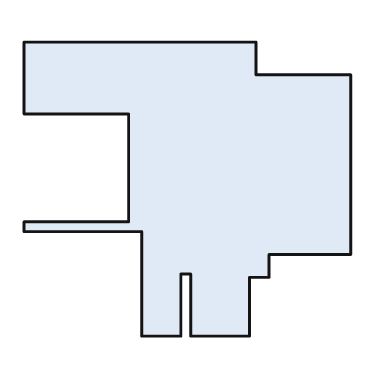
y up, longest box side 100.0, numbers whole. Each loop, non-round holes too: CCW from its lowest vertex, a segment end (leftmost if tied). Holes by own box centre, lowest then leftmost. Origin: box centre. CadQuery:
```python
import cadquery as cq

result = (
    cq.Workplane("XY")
    .moveTo(-14.0, -45.0)
    .lineTo(-2.0, -45.0)
    .lineTo(-2.0, -26.0)
    .lineTo(1.0, -26.0)
    .lineTo(1.0, -45.0)
    .lineTo(19.0, -45.0)
    .lineTo(19.0, -27.0)
    .lineTo(25.0, -27.0)
    .lineTo(25.0, -20.0)
    .lineTo(50.0, -20.0)
    .lineTo(50.0, 35.0)
    .lineTo(21.0, 35.0)
    .lineTo(21.0, 45.0)
    .lineTo(-50.0, 45.0)
    .lineTo(-50.0, 23.0)
    .lineTo(-18.0, 23.0)
    .lineTo(-18.0, -10.0)
    .lineTo(-50.0, -10.0)
    .lineTo(-50.0, -13.0)
    .lineTo(-14.0, -13.0)
    .close()
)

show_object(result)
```